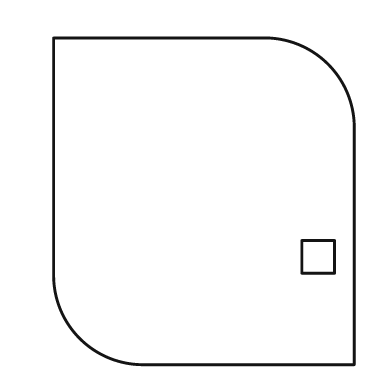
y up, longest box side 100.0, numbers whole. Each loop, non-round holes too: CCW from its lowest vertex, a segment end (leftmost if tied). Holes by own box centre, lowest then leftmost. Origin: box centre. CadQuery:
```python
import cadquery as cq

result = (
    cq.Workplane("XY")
    .moveTo(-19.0, -50.0)
    .lineTo(46.0, -50.0)
    .lineTo(46.0, 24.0)
    .threePointArc((38.0, 42.0), (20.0, 50.0))
    .lineTo(-46.0, 50.0)
    .lineTo(-46.0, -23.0)
    .threePointArc((-38.0, -42.0), (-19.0, -50.0))
    .close()
    .moveTo(30.0, -22.0)
    .lineTo(40.0, -22.0)
    .lineTo(40.0, -12.0)
    .lineTo(30.0, -12.0)
    .close()
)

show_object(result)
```